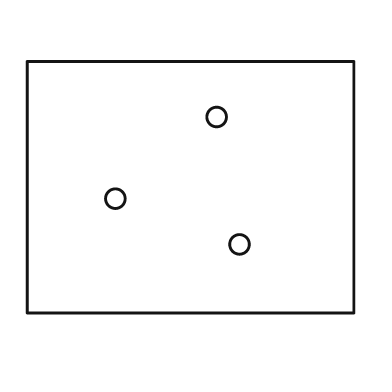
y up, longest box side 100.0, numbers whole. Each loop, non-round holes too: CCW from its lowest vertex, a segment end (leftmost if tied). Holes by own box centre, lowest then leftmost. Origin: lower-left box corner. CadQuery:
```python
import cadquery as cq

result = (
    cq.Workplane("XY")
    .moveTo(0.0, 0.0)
    .lineTo(100.0, 0.0)
    .lineTo(100.0, 77.0)
    .lineTo(0.0, 77.0)
    .close()
    .moveTo(65.0, 21.0)
    .circle(3.0)
    .moveTo(27.0, 35.0)
    .circle(3.0)
    .moveTo(58.0, 60.0)
    .circle(3.0)
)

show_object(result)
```